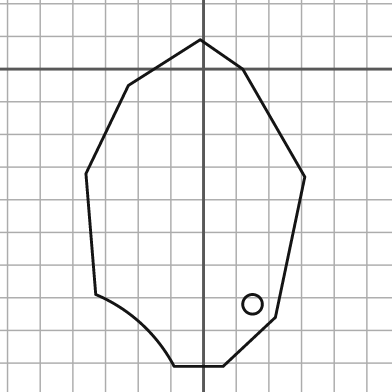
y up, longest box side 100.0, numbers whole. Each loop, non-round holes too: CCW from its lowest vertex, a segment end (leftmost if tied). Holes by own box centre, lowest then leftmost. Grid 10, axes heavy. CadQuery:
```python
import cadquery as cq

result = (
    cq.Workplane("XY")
    .moveTo(-9.0, -91.0)
    .lineTo(6.0, -91.0)
    .lineTo(22.0, -76.0)
    .lineTo(31.0, -33.0)
    .lineTo(12.0, 0.0)
    .lineTo(-1.0, 9.0)
    .lineTo(-23.0, -5.0)
    .lineTo(-36.0, -32.0)
    .lineTo(-33.0, -69.0)
    .threePointArc((-19.0, -78.0), (-9.0, -91.0))
    .close()
    .moveTo(15.0, -72.0)
    .circle(3.0)
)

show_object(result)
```